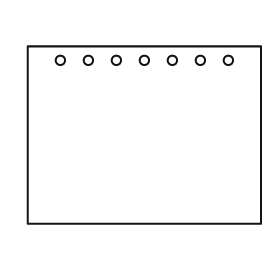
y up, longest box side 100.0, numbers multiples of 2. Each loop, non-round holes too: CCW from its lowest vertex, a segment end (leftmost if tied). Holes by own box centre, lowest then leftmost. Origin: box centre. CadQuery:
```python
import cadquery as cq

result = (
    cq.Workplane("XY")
    .moveTo(-50.0, -38.0)
    .lineTo(50.0, -38.0)
    .lineTo(50.0, 38.0)
    .lineTo(-50.0, 38.0)
    .close()
    .moveTo(-36.0, 32.0)
    .circle(2.0)
    .moveTo(-24.0, 32.0)
    .circle(2.0)
    .moveTo(-12.0, 32.0)
    .circle(2.0)
    .moveTo(0.0, 32.0)
    .circle(2.0)
    .moveTo(12.0, 32.0)
    .circle(2.0)
    .moveTo(24.0, 32.0)
    .circle(2.0)
    .moveTo(36.0, 32.0)
    .circle(2.0)
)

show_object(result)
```